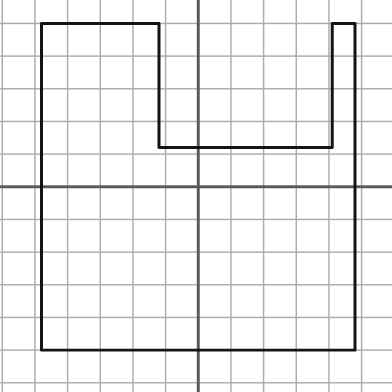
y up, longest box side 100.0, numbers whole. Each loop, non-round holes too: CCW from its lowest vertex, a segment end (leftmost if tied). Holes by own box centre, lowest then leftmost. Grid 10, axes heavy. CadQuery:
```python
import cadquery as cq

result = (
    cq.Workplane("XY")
    .moveTo(-48.0, -50.0)
    .lineTo(48.0, -50.0)
    .lineTo(48.0, 50.0)
    .lineTo(41.0, 50.0)
    .lineTo(41.0, 12.0)
    .lineTo(-12.0, 12.0)
    .lineTo(-12.0, 50.0)
    .lineTo(-48.0, 50.0)
    .close()
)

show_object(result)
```